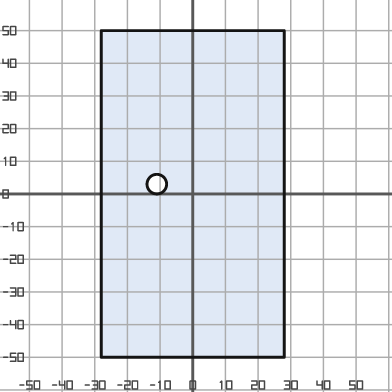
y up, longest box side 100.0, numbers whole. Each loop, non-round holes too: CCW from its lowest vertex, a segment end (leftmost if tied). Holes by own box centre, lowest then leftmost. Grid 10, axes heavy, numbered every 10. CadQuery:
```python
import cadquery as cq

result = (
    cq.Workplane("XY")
    .moveTo(-28.0, -50.0)
    .lineTo(28.0, -50.0)
    .lineTo(28.0, 50.0)
    .lineTo(-28.0, 50.0)
    .close()
    .moveTo(-11.0, 3.0)
    .circle(3.0)
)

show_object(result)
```